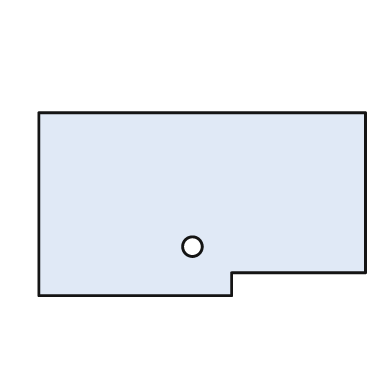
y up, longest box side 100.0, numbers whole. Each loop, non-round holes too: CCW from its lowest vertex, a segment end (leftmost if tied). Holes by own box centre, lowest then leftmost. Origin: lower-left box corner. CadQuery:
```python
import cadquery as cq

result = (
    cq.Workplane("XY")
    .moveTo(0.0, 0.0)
    .lineTo(59.0, 0.0)
    .lineTo(59.0, 7.0)
    .lineTo(100.0, 7.0)
    .lineTo(100.0, 56.0)
    .lineTo(0.0, 56.0)
    .close()
    .moveTo(47.0, 15.0)
    .circle(3.0)
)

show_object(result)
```